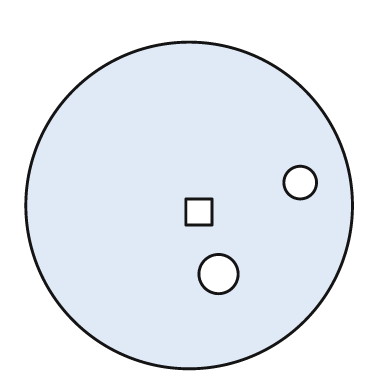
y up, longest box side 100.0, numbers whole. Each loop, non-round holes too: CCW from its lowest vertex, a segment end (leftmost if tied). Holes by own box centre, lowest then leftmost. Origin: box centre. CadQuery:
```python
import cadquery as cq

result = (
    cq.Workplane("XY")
    .moveTo(0.0, 0.0)
    .circle(50.0)
    .moveTo(9.0, -21.0)
    .circle(6.0)
    .moveTo(-1.0, -6.0)
    .lineTo(7.0, -6.0)
    .lineTo(7.0, 2.0)
    .lineTo(-1.0, 2.0)
    .close()
    .moveTo(34.0, 7.0)
    .circle(5.0)
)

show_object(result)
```